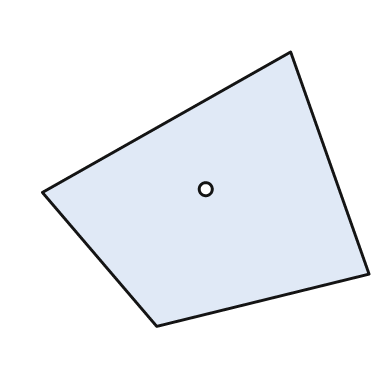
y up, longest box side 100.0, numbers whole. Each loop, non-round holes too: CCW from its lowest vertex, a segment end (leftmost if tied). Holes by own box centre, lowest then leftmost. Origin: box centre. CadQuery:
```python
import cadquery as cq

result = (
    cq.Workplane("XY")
    .moveTo(-15.0, -42.0)
    .lineTo(50.0, -26.0)
    .lineTo(26.0, 42.0)
    .lineTo(-50.0, -1.0)
    .close()
    .moveTo(0.0, 0.0)
    .circle(2.0)
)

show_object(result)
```